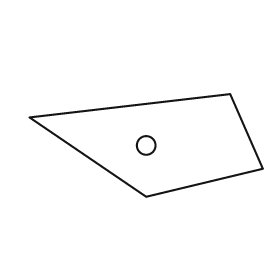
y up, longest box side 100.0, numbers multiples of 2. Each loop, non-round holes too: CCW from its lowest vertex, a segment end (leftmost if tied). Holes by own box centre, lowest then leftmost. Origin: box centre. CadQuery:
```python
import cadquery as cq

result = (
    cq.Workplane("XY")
    .moveTo(0.0, -22.0)
    .lineTo(50.0, -10.0)
    .lineTo(36.0, 22.0)
    .lineTo(-50.0, 12.0)
    .close()
    .moveTo(0.0, 0.0)
    .circle(4.0)
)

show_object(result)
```